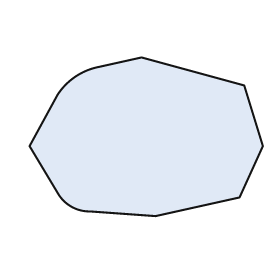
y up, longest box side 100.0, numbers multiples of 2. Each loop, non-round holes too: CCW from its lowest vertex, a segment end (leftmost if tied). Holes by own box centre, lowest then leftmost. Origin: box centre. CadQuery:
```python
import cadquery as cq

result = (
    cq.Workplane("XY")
    .moveTo(4.0, -34.0)
    .lineTo(40.0, -26.0)
    .lineTo(50.0, -4.0)
    .lineTo(42.0, 22.0)
    .lineTo(-2.0, 34.0)
    .lineTo(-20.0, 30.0)
    .threePointArc((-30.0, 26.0), (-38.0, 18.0))
    .lineTo(-50.0, -4.0)
    .lineTo(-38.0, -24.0)
    .threePointArc((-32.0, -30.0), (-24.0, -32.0))
    .close()
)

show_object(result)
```